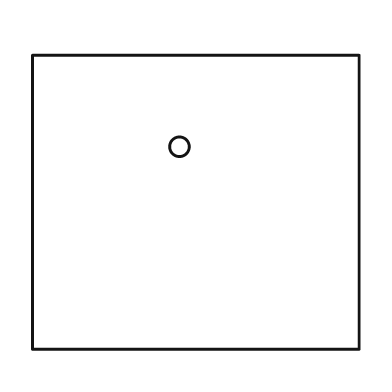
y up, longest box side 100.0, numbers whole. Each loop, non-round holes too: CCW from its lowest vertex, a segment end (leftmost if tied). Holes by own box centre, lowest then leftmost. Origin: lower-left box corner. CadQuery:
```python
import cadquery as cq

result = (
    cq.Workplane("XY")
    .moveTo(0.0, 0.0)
    .lineTo(100.0, 0.0)
    .lineTo(100.0, 90.0)
    .lineTo(0.0, 90.0)
    .close()
    .moveTo(45.0, 62.0)
    .circle(3.0)
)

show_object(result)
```